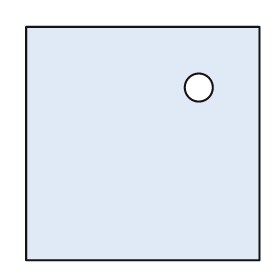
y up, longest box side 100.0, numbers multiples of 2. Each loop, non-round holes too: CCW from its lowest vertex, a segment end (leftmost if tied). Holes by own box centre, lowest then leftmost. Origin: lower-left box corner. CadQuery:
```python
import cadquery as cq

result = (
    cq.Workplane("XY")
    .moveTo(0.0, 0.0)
    .lineTo(100.0, 0.0)
    .lineTo(100.0, 100.0)
    .lineTo(0.0, 100.0)
    .close()
    .moveTo(74.0, 74.0)
    .circle(6.0)
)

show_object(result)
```